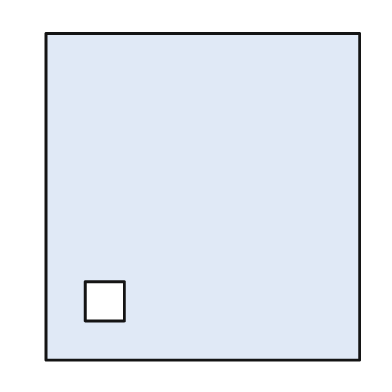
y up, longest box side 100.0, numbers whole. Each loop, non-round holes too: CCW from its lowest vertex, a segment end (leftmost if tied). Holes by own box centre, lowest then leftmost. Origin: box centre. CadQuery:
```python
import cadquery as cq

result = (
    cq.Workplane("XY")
    .moveTo(-48.0, -50.0)
    .lineTo(48.0, -50.0)
    .lineTo(48.0, 50.0)
    .lineTo(-48.0, 50.0)
    .close()
    .moveTo(-36.0, -38.0)
    .lineTo(-24.0, -38.0)
    .lineTo(-24.0, -26.0)
    .lineTo(-36.0, -26.0)
    .close()
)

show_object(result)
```